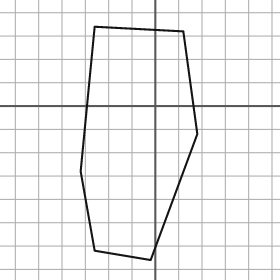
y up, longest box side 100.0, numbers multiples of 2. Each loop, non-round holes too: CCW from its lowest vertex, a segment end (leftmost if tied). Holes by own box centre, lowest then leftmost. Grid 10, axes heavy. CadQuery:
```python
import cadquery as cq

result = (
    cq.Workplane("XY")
    .moveTo(-2.0, -66.0)
    .lineTo(18.0, -12.0)
    .lineTo(12.0, 32.0)
    .lineTo(-26.0, 34.0)
    .lineTo(-32.0, -28.0)
    .lineTo(-26.0, -62.0)
    .close()
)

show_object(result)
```